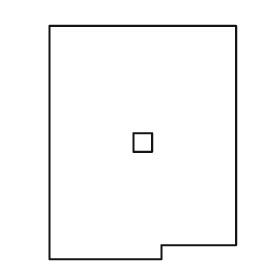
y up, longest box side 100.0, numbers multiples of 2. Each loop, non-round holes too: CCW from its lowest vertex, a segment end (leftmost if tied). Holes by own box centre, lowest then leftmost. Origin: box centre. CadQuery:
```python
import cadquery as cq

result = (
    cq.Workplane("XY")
    .moveTo(-40.0, -50.0)
    .lineTo(8.0, -50.0)
    .lineTo(8.0, -44.0)
    .lineTo(40.0, -44.0)
    .lineTo(40.0, 50.0)
    .lineTo(-40.0, 50.0)
    .close()
    .moveTo(-4.0, -4.0)
    .lineTo(4.0, -4.0)
    .lineTo(4.0, 4.0)
    .lineTo(-4.0, 4.0)
    .close()
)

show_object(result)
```